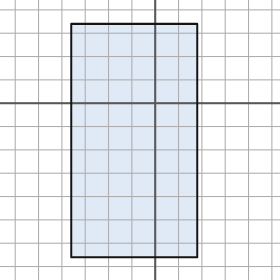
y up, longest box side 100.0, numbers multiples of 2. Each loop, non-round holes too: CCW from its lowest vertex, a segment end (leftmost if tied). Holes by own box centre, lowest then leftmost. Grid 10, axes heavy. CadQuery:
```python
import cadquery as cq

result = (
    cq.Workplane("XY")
    .moveTo(-36.0, -66.0)
    .lineTo(18.0, -66.0)
    .lineTo(18.0, 34.0)
    .lineTo(-36.0, 34.0)
    .close()
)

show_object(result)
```